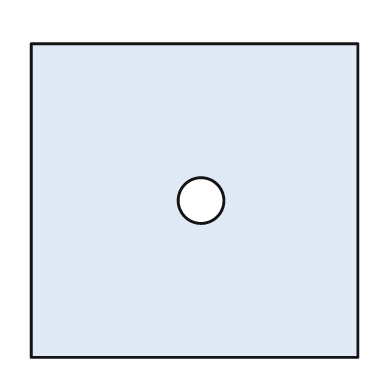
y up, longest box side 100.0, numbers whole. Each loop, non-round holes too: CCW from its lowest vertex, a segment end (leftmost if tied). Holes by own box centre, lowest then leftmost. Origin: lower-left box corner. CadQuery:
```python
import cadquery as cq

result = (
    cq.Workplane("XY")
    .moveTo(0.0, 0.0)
    .lineTo(100.0, 0.0)
    .lineTo(100.0, 96.0)
    .lineTo(0.0, 96.0)
    .close()
    .moveTo(52.0, 48.0)
    .circle(7.0)
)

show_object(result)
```